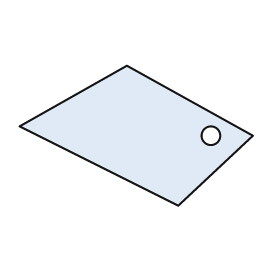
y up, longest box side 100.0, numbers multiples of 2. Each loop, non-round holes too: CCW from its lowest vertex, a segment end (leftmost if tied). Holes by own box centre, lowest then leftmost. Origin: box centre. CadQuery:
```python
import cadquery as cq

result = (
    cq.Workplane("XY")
    .moveTo(18.0, -30.0)
    .lineTo(50.0, 0.0)
    .lineTo(-4.0, 30.0)
    .lineTo(-50.0, 4.0)
    .close()
    .moveTo(32.0, 0.0)
    .circle(4.0)
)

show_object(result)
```